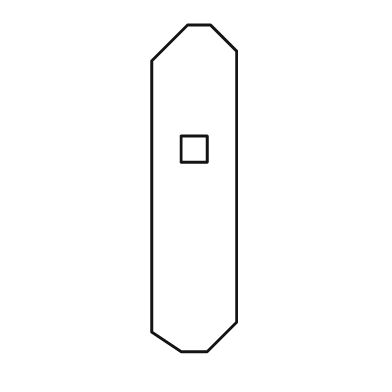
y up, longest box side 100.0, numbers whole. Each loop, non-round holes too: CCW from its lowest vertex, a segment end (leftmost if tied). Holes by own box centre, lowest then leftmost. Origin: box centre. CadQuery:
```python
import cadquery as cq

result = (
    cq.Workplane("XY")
    .moveTo(-4.0, -50.0)
    .lineTo(4.0, -50.0)
    .lineTo(13.0, -41.0)
    .lineTo(13.0, 42.0)
    .lineTo(5.0, 50.0)
    .lineTo(-2.0, 50.0)
    .lineTo(-13.0, 39.0)
    .lineTo(-13.0, -44.0)
    .close()
    .moveTo(-4.0, 8.0)
    .lineTo(4.0, 8.0)
    .lineTo(4.0, 16.0)
    .lineTo(-4.0, 16.0)
    .close()
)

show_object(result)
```